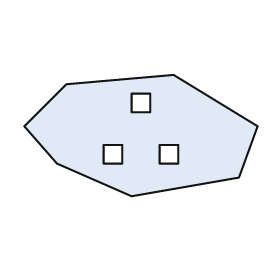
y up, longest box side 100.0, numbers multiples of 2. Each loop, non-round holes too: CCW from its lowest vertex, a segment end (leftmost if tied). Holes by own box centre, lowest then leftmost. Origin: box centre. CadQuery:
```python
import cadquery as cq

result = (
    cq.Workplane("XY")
    .moveTo(-4.0, -26.0)
    .lineTo(42.0, -18.0)
    .lineTo(50.0, 4.0)
    .lineTo(14.0, 26.0)
    .lineTo(-32.0, 22.0)
    .lineTo(-50.0, 4.0)
    .lineTo(-36.0, -12.0)
    .close()
    .moveTo(-16.0, -12.0)
    .lineTo(-8.0, -12.0)
    .lineTo(-8.0, -4.0)
    .lineTo(-16.0, -4.0)
    .close()
    .moveTo(8.0, -12.0)
    .lineTo(16.0, -12.0)
    .lineTo(16.0, -4.0)
    .lineTo(8.0, -4.0)
    .close()
    .moveTo(-4.0, 10.0)
    .lineTo(4.0, 10.0)
    .lineTo(4.0, 18.0)
    .lineTo(-4.0, 18.0)
    .close()
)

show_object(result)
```